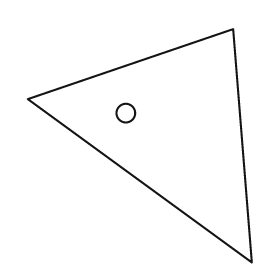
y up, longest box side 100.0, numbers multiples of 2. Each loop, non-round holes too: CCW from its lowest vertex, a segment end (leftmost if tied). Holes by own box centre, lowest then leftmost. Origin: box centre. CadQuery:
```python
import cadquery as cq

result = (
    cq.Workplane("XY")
    .moveTo(48.0, -50.0)
    .lineTo(40.0, 50.0)
    .lineTo(-48.0, 20.0)
    .close()
    .moveTo(-6.0, 14.0)
    .circle(4.0)
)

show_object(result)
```